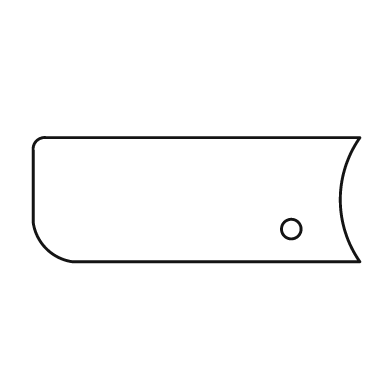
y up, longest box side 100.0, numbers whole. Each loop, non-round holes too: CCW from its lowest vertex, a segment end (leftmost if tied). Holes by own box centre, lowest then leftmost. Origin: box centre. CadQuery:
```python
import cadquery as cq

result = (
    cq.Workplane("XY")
    .moveTo(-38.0, -19.0)
    .lineTo(50.0, -19.0)
    .threePointArc((44.0, 0.0), (50.0, 19.0))
    .lineTo(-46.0, 19.0)
    .threePointArc((-49.0, 18.0), (-50.0, 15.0))
    .lineTo(-50.0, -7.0)
    .threePointArc((-46.0, -15.0), (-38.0, -19.0))
    .close()
    .moveTo(29.0, -9.0)
    .circle(3.0)
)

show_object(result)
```